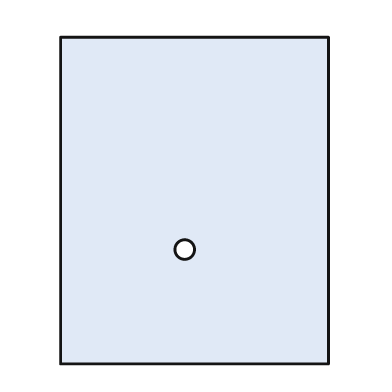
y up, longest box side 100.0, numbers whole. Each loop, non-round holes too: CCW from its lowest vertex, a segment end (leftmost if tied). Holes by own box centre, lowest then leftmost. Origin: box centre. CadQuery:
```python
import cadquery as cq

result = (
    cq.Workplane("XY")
    .moveTo(-41.0, -50.0)
    .lineTo(41.0, -50.0)
    .lineTo(41.0, 50.0)
    .lineTo(-41.0, 50.0)
    .close()
    .moveTo(-3.0, -15.0)
    .circle(3.0)
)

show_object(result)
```